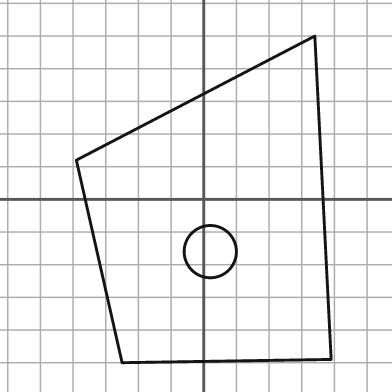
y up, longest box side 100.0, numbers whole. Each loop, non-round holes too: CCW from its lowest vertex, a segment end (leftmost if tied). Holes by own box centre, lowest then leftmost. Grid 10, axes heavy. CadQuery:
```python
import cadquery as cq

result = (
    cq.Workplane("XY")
    .moveTo(-25.0, -50.0)
    .lineTo(39.0, -49.0)
    .lineTo(34.0, 50.0)
    .lineTo(-39.0, 12.0)
    .close()
    .moveTo(2.0, -16.0)
    .circle(8.0)
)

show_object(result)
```